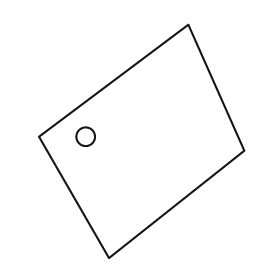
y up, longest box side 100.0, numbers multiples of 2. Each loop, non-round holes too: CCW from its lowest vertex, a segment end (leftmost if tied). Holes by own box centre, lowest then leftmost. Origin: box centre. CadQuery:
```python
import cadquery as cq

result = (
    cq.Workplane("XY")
    .moveTo(-14.0, -50.0)
    .lineTo(44.0, -4.0)
    .lineTo(20.0, 50.0)
    .lineTo(-44.0, 2.0)
    .close()
    .moveTo(-24.0, 2.0)
    .circle(4.0)
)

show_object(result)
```